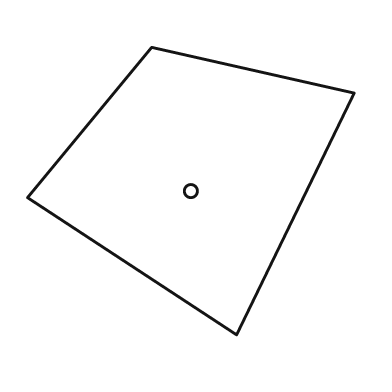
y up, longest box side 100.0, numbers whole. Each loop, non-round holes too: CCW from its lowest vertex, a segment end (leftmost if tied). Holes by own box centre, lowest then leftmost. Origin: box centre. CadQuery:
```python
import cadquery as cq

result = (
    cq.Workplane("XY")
    .moveTo(14.0, -44.0)
    .lineTo(50.0, 30.0)
    .lineTo(-12.0, 44.0)
    .lineTo(-50.0, -2.0)
    .close()
    .moveTo(0.0, 0.0)
    .circle(2.0)
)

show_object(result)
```